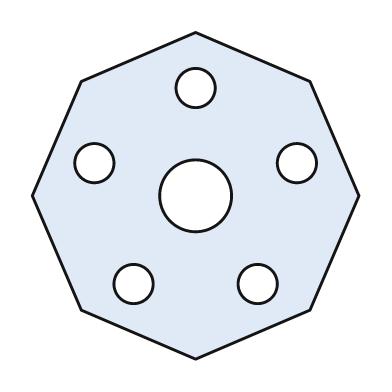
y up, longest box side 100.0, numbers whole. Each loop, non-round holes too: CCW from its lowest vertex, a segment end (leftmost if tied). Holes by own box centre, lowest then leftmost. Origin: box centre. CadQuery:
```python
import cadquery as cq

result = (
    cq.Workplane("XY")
    .moveTo(0.0, -50.0)
    .lineTo(35.0, -35.0)
    .lineTo(50.0, 0.0)
    .lineTo(35.0, 35.0)
    .lineTo(0.0, 50.0)
    .lineTo(-35.0, 35.0)
    .lineTo(-50.0, 0.0)
    .lineTo(-35.0, -35.0)
    .close()
    .moveTo(-19.0, -27.0)
    .circle(6.0)
    .moveTo(19.0, -27.0)
    .circle(6.0)
    .moveTo(0.0, 0.0)
    .circle(11.0)
    .moveTo(-31.0, 10.0)
    .circle(6.0)
    .moveTo(31.0, 10.0)
    .circle(6.0)
    .moveTo(0.0, 33.0)
    .circle(6.0)
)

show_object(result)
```